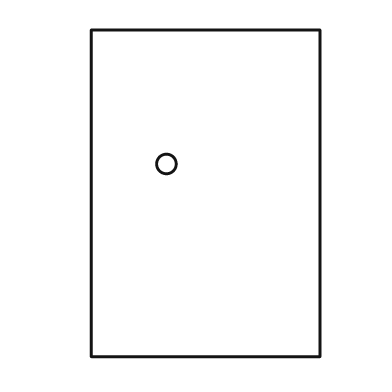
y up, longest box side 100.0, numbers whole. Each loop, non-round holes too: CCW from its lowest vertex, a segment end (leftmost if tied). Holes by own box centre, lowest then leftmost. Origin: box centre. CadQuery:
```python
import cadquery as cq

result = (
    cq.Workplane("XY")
    .moveTo(-35.0, -50.0)
    .lineTo(35.0, -50.0)
    .lineTo(35.0, 50.0)
    .lineTo(-35.0, 50.0)
    .close()
    .moveTo(-12.0, 9.0)
    .circle(3.0)
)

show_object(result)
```